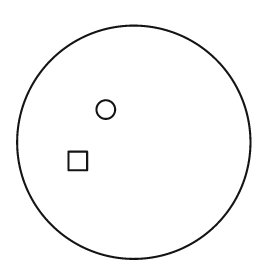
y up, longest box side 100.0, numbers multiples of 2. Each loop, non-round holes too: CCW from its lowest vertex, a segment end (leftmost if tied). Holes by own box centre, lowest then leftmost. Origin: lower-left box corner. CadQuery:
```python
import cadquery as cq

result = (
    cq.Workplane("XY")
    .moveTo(50.0, 50.0)
    .circle(50.0)
    .moveTo(22.0, 38.0)
    .lineTo(30.0, 38.0)
    .lineTo(30.0, 46.0)
    .lineTo(22.0, 46.0)
    .close()
    .moveTo(38.0, 64.0)
    .circle(4.0)
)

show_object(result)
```